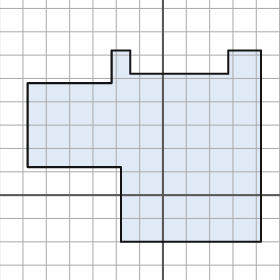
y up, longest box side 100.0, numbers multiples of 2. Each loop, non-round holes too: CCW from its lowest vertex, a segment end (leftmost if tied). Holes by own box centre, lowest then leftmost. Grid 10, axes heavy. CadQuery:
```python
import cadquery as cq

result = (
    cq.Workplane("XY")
    .moveTo(-18.0, -20.0)
    .lineTo(42.0, -20.0)
    .lineTo(42.0, 62.0)
    .lineTo(28.0, 62.0)
    .lineTo(28.0, 52.0)
    .lineTo(-14.0, 52.0)
    .lineTo(-14.0, 62.0)
    .lineTo(-22.0, 62.0)
    .lineTo(-22.0, 48.0)
    .lineTo(-58.0, 48.0)
    .lineTo(-58.0, 12.0)
    .lineTo(-18.0, 12.0)
    .close()
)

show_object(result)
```